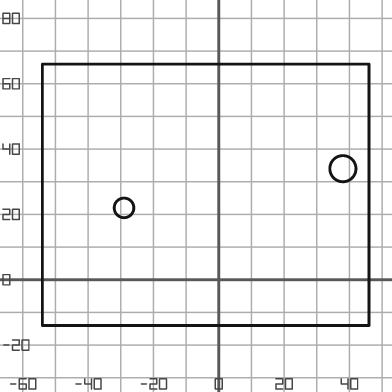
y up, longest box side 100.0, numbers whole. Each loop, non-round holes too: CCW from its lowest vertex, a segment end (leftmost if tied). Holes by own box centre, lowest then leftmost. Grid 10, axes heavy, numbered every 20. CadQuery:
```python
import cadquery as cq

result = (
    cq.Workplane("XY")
    .moveTo(-54.0, -14.0)
    .lineTo(46.0, -14.0)
    .lineTo(46.0, 66.0)
    .lineTo(-54.0, 66.0)
    .close()
    .moveTo(-29.0, 22.0)
    .circle(3.0)
    .moveTo(38.0, 34.0)
    .circle(4.0)
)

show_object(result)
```